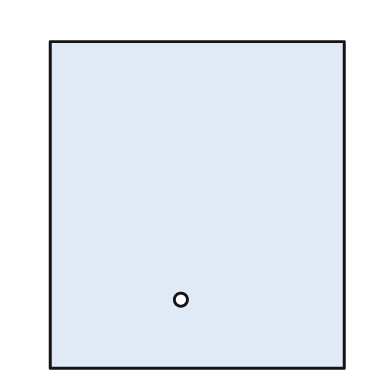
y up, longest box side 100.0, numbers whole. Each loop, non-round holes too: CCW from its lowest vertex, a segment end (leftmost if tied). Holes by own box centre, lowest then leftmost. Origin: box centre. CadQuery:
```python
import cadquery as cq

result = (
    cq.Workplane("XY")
    .moveTo(-45.0, -50.0)
    .lineTo(45.0, -50.0)
    .lineTo(45.0, 50.0)
    .lineTo(-45.0, 50.0)
    .close()
    .moveTo(-5.0, -29.0)
    .circle(2.0)
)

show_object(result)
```